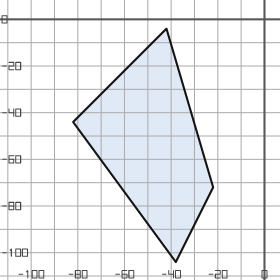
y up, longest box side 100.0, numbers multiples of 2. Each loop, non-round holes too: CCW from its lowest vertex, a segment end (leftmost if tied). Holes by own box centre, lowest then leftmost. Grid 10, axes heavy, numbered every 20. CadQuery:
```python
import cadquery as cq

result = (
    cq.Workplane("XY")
    .moveTo(-38.0, -104.0)
    .lineTo(-22.0, -72.0)
    .lineTo(-42.0, -4.0)
    .lineTo(-82.0, -44.0)
    .close()
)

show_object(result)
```